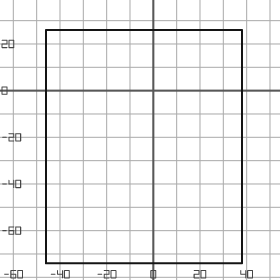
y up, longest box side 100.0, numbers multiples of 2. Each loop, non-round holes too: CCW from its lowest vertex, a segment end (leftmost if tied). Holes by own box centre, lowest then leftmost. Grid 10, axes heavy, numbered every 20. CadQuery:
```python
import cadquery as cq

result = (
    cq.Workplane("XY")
    .moveTo(-46.0, -74.0)
    .lineTo(38.0, -74.0)
    .lineTo(38.0, 26.0)
    .lineTo(-46.0, 26.0)
    .close()
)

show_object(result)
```